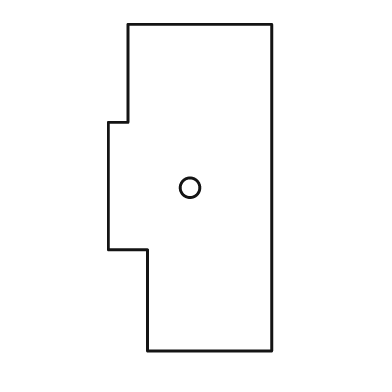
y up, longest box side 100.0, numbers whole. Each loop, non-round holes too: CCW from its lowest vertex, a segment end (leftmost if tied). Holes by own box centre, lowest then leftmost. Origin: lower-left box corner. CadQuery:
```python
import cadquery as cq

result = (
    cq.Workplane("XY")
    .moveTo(12.0, 0.0)
    .lineTo(50.0, 0.0)
    .lineTo(50.0, 100.0)
    .lineTo(6.0, 100.0)
    .lineTo(6.0, 70.0)
    .lineTo(0.0, 70.0)
    .lineTo(0.0, 31.0)
    .lineTo(12.0, 31.0)
    .close()
    .moveTo(25.0, 50.0)
    .circle(3.0)
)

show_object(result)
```